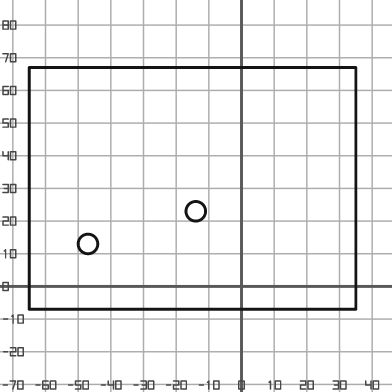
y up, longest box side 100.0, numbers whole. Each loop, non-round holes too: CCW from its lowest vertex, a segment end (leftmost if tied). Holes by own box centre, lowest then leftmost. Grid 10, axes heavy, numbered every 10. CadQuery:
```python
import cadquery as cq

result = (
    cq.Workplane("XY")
    .moveTo(-65.0, -7.0)
    .lineTo(35.0, -7.0)
    .lineTo(35.0, 67.0)
    .lineTo(-65.0, 67.0)
    .close()
    .moveTo(-47.0, 13.0)
    .circle(3.0)
    .moveTo(-14.0, 23.0)
    .circle(3.0)
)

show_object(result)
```